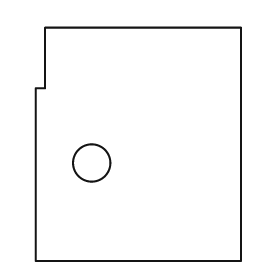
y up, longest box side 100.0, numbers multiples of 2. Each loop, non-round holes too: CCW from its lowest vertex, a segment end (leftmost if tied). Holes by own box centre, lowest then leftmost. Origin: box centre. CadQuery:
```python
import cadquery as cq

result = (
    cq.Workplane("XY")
    .moveTo(-44.0, -50.0)
    .lineTo(44.0, -50.0)
    .lineTo(44.0, 50.0)
    .lineTo(-40.0, 50.0)
    .lineTo(-40.0, 24.0)
    .lineTo(-44.0, 24.0)
    .close()
    .moveTo(-20.0, -8.0)
    .circle(8.0)
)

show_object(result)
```